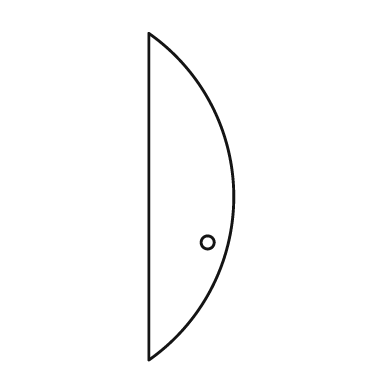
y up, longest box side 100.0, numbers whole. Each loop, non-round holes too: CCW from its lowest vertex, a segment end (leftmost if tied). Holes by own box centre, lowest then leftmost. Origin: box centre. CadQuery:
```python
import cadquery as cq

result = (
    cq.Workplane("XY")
    .moveTo(-13.0, -50.0)
    .threePointArc((13.0, 0.0), (-13.0, 50.0))
    .close()
    .moveTo(5.0, -14.0)
    .circle(2.0)
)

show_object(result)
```